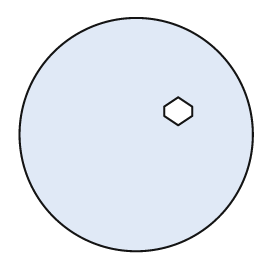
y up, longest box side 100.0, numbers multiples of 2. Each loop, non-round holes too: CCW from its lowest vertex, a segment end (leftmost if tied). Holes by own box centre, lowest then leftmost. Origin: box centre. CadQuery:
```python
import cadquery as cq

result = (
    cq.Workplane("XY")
    .moveTo(0.0, 0.0)
    .circle(50.0)
    .moveTo(18.0, 4.0)
    .lineTo(24.0, 8.0)
    .lineTo(24.0, 12.0)
    .lineTo(18.0, 16.0)
    .lineTo(12.0, 12.0)
    .lineTo(12.0, 8.0)
    .close()
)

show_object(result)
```